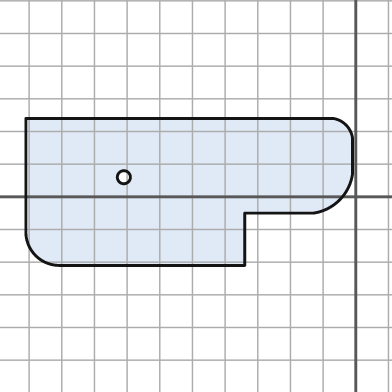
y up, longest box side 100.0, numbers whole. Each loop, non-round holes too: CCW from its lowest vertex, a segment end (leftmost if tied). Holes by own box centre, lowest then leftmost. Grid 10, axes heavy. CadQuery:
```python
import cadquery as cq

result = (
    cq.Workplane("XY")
    .moveTo(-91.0, -21.0)
    .lineTo(-34.0, -21.0)
    .lineTo(-34.0, -5.0)
    .lineTo(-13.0, -5.0)
    .threePointArc((-5.0, -1.0), (-1.0, 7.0))
    .lineTo(-1.0, 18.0)
    .threePointArc((-3.0, 22.0), (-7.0, 24.0))
    .lineTo(-101.0, 24.0)
    .lineTo(-101.0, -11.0)
    .threePointArc((-98.0, -18.0), (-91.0, -21.0))
    .close()
    .moveTo(-71.0, 6.0)
    .circle(2.0)
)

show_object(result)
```